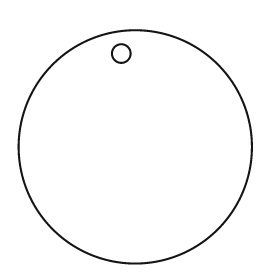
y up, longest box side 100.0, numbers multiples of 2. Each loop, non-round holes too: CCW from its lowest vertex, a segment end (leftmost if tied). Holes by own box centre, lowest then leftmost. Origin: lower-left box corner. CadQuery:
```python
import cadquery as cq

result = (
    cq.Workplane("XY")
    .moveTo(50.0, 50.0)
    .circle(50.0)
    .moveTo(44.0, 90.0)
    .circle(4.0)
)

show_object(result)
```